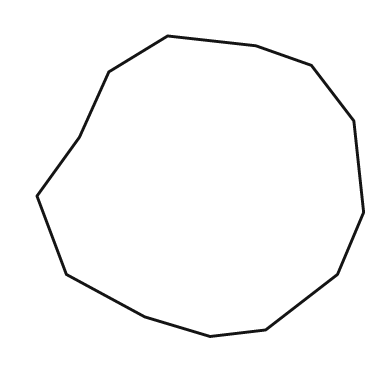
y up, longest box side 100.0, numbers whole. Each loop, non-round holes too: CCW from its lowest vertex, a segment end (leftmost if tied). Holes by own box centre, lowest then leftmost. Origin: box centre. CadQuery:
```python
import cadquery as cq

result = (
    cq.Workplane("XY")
    .moveTo(3.0, -46.0)
    .lineTo(20.0, -44.0)
    .lineTo(42.0, -27.0)
    .lineTo(50.0, -8.0)
    .lineTo(47.0, 20.0)
    .lineTo(34.0, 37.0)
    .lineTo(17.0, 43.0)
    .lineTo(-10.0, 46.0)
    .lineTo(-28.0, 35.0)
    .lineTo(-37.0, 15.0)
    .lineTo(-50.0, -3.0)
    .lineTo(-41.0, -27.0)
    .lineTo(-17.0, -40.0)
    .close()
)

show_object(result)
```